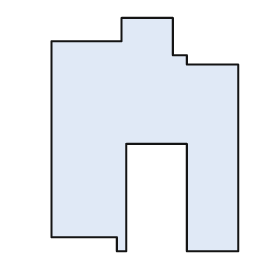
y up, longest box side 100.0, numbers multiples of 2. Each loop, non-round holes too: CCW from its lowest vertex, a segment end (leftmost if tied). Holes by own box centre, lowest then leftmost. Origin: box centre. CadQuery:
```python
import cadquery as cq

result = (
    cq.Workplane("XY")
    .moveTo(-12.0, -50.0)
    .lineTo(-8.0, -50.0)
    .lineTo(-8.0, -4.0)
    .lineTo(18.0, -4.0)
    .lineTo(18.0, -50.0)
    .lineTo(40.0, -50.0)
    .lineTo(40.0, 30.0)
    .lineTo(18.0, 30.0)
    .lineTo(18.0, 34.0)
    .lineTo(12.0, 34.0)
    .lineTo(12.0, 50.0)
    .lineTo(-10.0, 50.0)
    .lineTo(-10.0, 40.0)
    .lineTo(-40.0, 40.0)
    .lineTo(-40.0, -44.0)
    .lineTo(-12.0, -44.0)
    .close()
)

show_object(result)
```